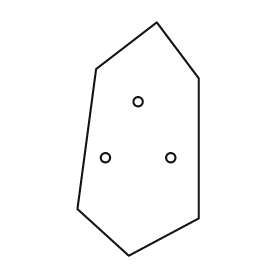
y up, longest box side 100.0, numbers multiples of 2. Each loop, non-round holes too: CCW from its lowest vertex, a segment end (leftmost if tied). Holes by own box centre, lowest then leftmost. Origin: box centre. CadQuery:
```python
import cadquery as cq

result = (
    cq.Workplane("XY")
    .moveTo(-4.0, -50.0)
    .lineTo(26.0, -34.0)
    .lineTo(26.0, 26.0)
    .lineTo(8.0, 50.0)
    .lineTo(-18.0, 30.0)
    .lineTo(-26.0, -30.0)
    .close()
    .moveTo(-14.0, -8.0)
    .circle(2.0)
    .moveTo(14.0, -8.0)
    .circle(2.0)
    .moveTo(0.0, 16.0)
    .circle(2.0)
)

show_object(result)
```